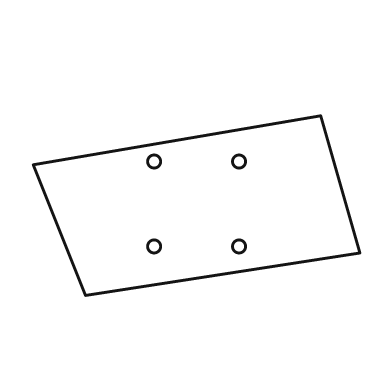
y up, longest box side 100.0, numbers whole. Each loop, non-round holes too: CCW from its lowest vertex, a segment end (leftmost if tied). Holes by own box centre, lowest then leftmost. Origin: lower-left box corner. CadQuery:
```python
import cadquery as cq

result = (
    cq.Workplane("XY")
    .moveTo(16.0, 0.0)
    .lineTo(100.0, 13.0)
    .lineTo(88.0, 55.0)
    .lineTo(0.0, 40.0)
    .close()
    .moveTo(37.0, 15.0)
    .circle(2.0)
    .moveTo(63.0, 15.0)
    .circle(2.0)
    .moveTo(37.0, 41.0)
    .circle(2.0)
    .moveTo(63.0, 41.0)
    .circle(2.0)
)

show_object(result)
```